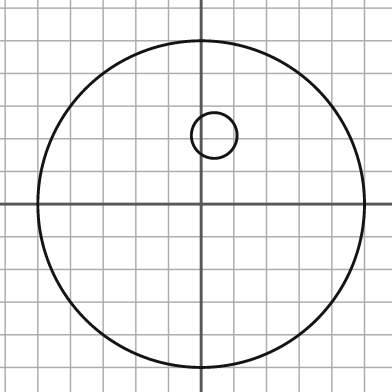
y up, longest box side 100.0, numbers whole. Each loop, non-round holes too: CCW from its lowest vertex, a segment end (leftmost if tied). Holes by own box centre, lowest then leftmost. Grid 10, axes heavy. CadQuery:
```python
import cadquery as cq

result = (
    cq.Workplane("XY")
    .moveTo(0.0, 0.0)
    .circle(50.0)
    .moveTo(4.0, 21.0)
    .circle(7.0)
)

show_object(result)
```